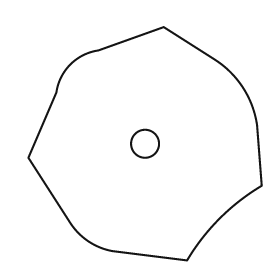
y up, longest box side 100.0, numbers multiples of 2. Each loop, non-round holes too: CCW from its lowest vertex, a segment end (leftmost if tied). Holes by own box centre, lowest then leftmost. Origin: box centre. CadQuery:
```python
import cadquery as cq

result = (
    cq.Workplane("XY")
    .moveTo(18.0, -50.0)
    .threePointArc((32.0, -32.0), (50.0, -18.0))
    .lineTo(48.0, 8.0)
    .threePointArc((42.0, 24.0), (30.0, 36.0))
    .lineTo(8.0, 50.0)
    .lineTo(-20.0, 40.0)
    .threePointArc((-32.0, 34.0), (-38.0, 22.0))
    .lineTo(-50.0, -6.0)
    .lineTo(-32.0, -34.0)
    .threePointArc((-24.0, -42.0), (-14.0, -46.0))
    .close()
    .moveTo(0.0, 0.0)
    .circle(6.0)
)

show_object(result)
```